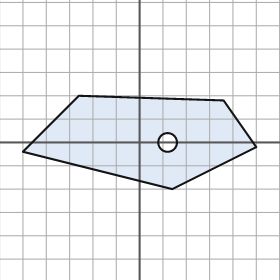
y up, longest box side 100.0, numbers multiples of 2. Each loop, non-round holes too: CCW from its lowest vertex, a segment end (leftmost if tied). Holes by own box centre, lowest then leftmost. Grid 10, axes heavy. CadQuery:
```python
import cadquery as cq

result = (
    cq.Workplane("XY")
    .moveTo(14.0, -20.0)
    .lineTo(50.0, -2.0)
    .lineTo(36.0, 18.0)
    .lineTo(-26.0, 20.0)
    .lineTo(-50.0, -4.0)
    .close()
    .moveTo(12.0, 0.0)
    .circle(4.0)
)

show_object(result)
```